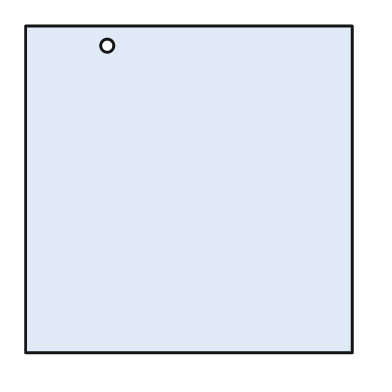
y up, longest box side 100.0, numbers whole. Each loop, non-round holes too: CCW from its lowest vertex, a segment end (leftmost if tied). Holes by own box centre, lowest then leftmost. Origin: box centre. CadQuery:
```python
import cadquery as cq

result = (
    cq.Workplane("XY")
    .moveTo(-50.0, -50.0)
    .lineTo(50.0, -50.0)
    .lineTo(50.0, 50.0)
    .lineTo(-50.0, 50.0)
    .close()
    .moveTo(-25.0, 44.0)
    .circle(2.0)
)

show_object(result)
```